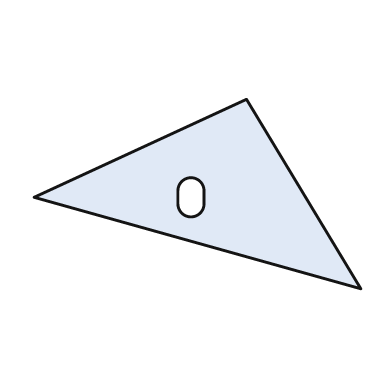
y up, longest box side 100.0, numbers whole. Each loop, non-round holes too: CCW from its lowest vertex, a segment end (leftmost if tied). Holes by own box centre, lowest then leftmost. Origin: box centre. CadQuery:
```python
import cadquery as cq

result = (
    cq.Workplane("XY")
    .moveTo(50.0, -29.0)
    .lineTo(15.0, 29.0)
    .lineTo(-50.0, -1.0)
    .close()
    .moveTo(-6.0, -3.0)
    .threePointArc((-2.0, -7.0), (2.0, -3.0))
    .lineTo(2.0, 1.0)
    .threePointArc((-2.0, 5.0), (-6.0, 1.0))
    .close()
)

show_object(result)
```